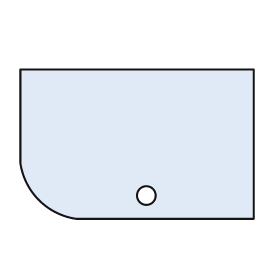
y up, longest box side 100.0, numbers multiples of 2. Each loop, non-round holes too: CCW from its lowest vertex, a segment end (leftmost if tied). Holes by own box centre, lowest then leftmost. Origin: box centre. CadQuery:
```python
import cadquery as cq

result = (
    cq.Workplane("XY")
    .moveTo(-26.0, -32.0)
    .lineTo(50.0, -32.0)
    .lineTo(50.0, 32.0)
    .lineTo(-50.0, 32.0)
    .lineTo(-50.0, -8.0)
    .threePointArc((-42.0, -24.0), (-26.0, -32.0))
    .close()
    .moveTo(4.0, -22.0)
    .circle(4.0)
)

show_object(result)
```